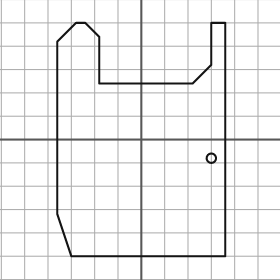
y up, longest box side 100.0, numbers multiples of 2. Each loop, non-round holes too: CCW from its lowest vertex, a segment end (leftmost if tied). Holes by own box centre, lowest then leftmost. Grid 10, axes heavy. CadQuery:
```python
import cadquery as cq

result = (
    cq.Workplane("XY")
    .moveTo(-30.0, -50.0)
    .lineTo(36.0, -50.0)
    .lineTo(36.0, 50.0)
    .lineTo(30.0, 50.0)
    .lineTo(30.0, 32.0)
    .lineTo(22.0, 24.0)
    .lineTo(-18.0, 24.0)
    .lineTo(-18.0, 44.0)
    .lineTo(-24.0, 50.0)
    .lineTo(-28.0, 50.0)
    .lineTo(-36.0, 42.0)
    .lineTo(-36.0, -32.0)
    .close()
    .moveTo(30.0, -8.0)
    .circle(2.0)
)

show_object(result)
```